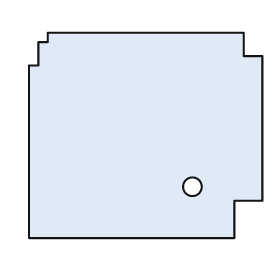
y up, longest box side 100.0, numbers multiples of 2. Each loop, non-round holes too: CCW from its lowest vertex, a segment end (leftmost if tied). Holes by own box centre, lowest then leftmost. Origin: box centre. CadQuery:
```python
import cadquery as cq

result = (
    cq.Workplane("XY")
    .moveTo(-50.0, -44.0)
    .lineTo(38.0, -44.0)
    .lineTo(38.0, -28.0)
    .lineTo(50.0, -28.0)
    .lineTo(50.0, 34.0)
    .lineTo(42.0, 34.0)
    .lineTo(42.0, 44.0)
    .lineTo(-42.0, 44.0)
    .lineTo(-42.0, 40.0)
    .lineTo(-46.0, 40.0)
    .lineTo(-46.0, 30.0)
    .lineTo(-50.0, 30.0)
    .close()
    .moveTo(20.0, -22.0)
    .circle(4.0)
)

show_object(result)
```